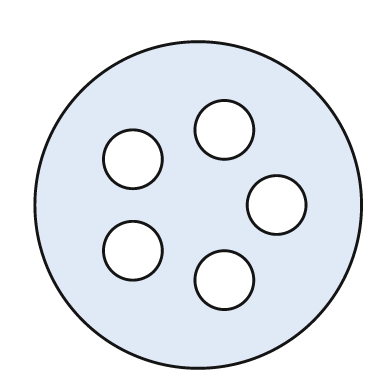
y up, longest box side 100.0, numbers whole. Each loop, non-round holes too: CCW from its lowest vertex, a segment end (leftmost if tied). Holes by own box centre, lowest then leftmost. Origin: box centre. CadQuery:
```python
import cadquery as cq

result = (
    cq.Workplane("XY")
    .moveTo(0.0, 0.0)
    .circle(50.0)
    .moveTo(8.0, -23.0)
    .circle(9.0)
    .moveTo(-20.0, -14.0)
    .circle(9.0)
    .moveTo(24.0, 0.0)
    .circle(9.0)
    .moveTo(-20.0, 14.0)
    .circle(9.0)
    .moveTo(8.0, 23.0)
    .circle(9.0)
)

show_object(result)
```